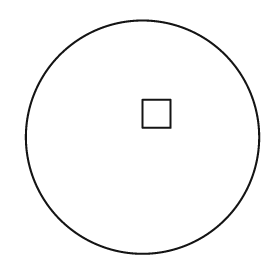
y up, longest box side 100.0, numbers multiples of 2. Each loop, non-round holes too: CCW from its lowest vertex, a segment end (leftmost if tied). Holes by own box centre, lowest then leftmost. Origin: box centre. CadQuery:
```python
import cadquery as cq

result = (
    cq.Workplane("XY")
    .moveTo(0.0, 0.0)
    .circle(50.0)
    .moveTo(0.0, 4.0)
    .lineTo(12.0, 4.0)
    .lineTo(12.0, 16.0)
    .lineTo(0.0, 16.0)
    .close()
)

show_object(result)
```